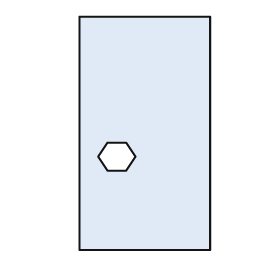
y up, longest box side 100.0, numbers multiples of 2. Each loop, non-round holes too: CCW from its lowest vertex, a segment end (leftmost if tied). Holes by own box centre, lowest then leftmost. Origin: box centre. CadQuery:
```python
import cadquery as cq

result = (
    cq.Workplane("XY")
    .moveTo(-28.0, -50.0)
    .lineTo(28.0, -50.0)
    .lineTo(28.0, 50.0)
    .lineTo(-28.0, 50.0)
    .close()
    .moveTo(-16.0, -16.0)
    .lineTo(-8.0, -16.0)
    .lineTo(-4.0, -10.0)
    .lineTo(-8.0, -4.0)
    .lineTo(-16.0, -4.0)
    .lineTo(-20.0, -10.0)
    .close()
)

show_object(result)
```